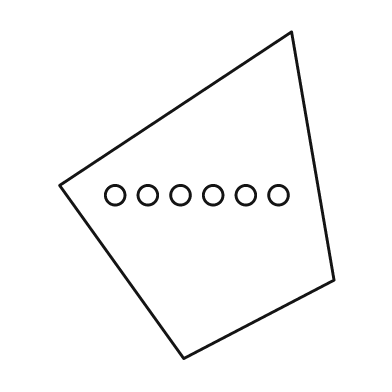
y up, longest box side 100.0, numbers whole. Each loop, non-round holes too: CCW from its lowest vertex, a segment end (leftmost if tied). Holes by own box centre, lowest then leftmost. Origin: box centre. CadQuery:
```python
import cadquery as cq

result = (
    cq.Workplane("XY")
    .moveTo(-4.0, -50.0)
    .lineTo(42.0, -26.0)
    .lineTo(29.0, 50.0)
    .lineTo(-42.0, 3.0)
    .close()
    .moveTo(-25.0, 0.0)
    .circle(3.0)
    .moveTo(-15.0, 0.0)
    .circle(3.0)
    .moveTo(-5.0, 0.0)
    .circle(3.0)
    .moveTo(5.0, 0.0)
    .circle(3.0)
    .moveTo(15.0, 0.0)
    .circle(3.0)
    .moveTo(25.0, 0.0)
    .circle(3.0)
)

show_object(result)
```